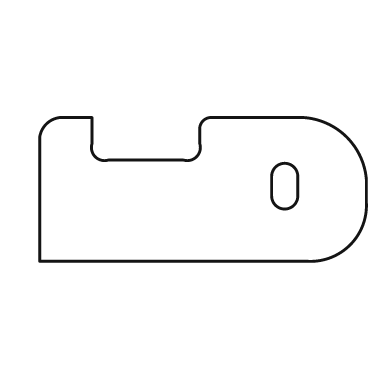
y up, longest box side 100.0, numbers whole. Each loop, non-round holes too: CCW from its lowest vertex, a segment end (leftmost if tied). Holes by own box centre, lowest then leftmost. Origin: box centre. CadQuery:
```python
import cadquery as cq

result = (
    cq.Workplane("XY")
    .moveTo(-50.0, -22.0)
    .lineTo(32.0, -22.0)
    .threePointArc((45.0, -17.0), (50.0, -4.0))
    .lineTo(50.0, 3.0)
    .threePointArc((44.0, 16.0), (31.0, 22.0))
    .lineTo(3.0, 22.0)
    .threePointArc((0.0, 21.0), (-1.0, 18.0))
    .lineTo(-1.0, 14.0)
    .threePointArc((-2.0, 10.0), (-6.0, 9.0))
    .lineTo(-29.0, 9.0)
    .threePointArc((-33.0, 10.0), (-34.0, 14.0))
    .lineTo(-34.0, 22.0)
    .lineTo(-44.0, 22.0)
    .threePointArc((-48.0, 20.0), (-50.0, 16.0))
    .close()
    .moveTo(21.0, -2.0)
    .threePointArc((25.0, -6.0), (29.0, -2.0))
    .lineTo(29.0, 4.0)
    .threePointArc((25.0, 8.0), (21.0, 4.0))
    .close()
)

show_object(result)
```